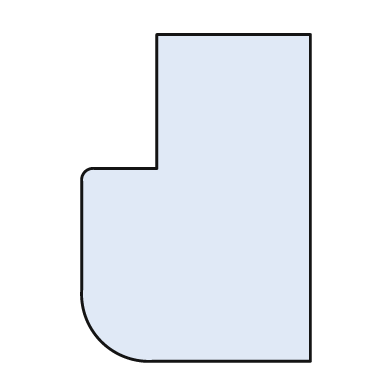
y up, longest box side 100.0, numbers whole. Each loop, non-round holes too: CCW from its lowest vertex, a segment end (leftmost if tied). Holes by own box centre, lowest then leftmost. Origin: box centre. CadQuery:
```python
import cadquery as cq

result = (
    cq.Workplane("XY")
    .moveTo(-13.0, -50.0)
    .lineTo(35.0, -50.0)
    .lineTo(35.0, 50.0)
    .lineTo(-12.0, 50.0)
    .lineTo(-12.0, 9.0)
    .lineTo(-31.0, 9.0)
    .threePointArc((-34.0, 8.0), (-35.0, 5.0))
    .lineTo(-35.0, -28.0)
    .threePointArc((-29.0, -44.0), (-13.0, -50.0))
    .close()
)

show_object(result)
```